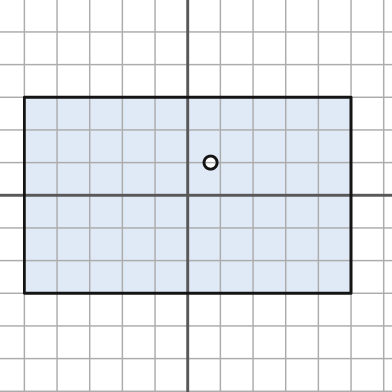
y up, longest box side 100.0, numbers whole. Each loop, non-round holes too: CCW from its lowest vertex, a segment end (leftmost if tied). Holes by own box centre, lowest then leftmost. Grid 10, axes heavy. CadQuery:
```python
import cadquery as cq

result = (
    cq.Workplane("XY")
    .moveTo(-50.0, -30.0)
    .lineTo(50.0, -30.0)
    .lineTo(50.0, 30.0)
    .lineTo(-50.0, 30.0)
    .close()
    .moveTo(7.0, 10.0)
    .circle(2.0)
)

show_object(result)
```